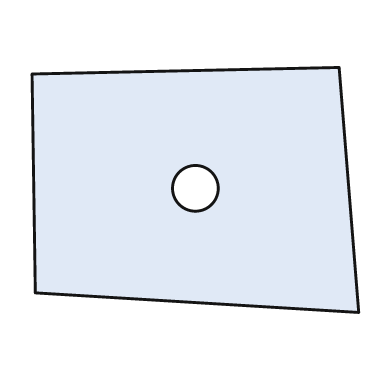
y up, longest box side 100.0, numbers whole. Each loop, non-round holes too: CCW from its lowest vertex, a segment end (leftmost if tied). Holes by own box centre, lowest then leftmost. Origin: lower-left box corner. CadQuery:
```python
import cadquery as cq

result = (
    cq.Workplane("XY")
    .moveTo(100.0, 0.0)
    .lineTo(94.0, 75.0)
    .lineTo(0.0, 73.0)
    .lineTo(1.0, 6.0)
    .close()
    .moveTo(50.0, 38.0)
    .circle(7.0)
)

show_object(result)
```